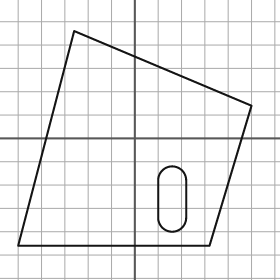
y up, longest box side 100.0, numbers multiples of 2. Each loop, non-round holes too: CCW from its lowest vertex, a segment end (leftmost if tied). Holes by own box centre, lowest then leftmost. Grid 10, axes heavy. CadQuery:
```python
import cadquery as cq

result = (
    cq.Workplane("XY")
    .moveTo(-50.0, -46.0)
    .lineTo(32.0, -46.0)
    .lineTo(50.0, 14.0)
    .lineTo(-26.0, 46.0)
    .close()
    .moveTo(10.0, -34.0)
    .threePointArc((16.0, -40.0), (22.0, -34.0))
    .lineTo(22.0, -18.0)
    .threePointArc((16.0, -12.0), (10.0, -18.0))
    .close()
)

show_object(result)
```